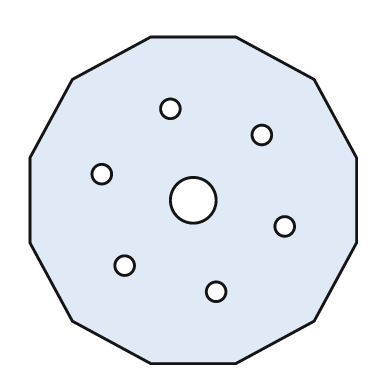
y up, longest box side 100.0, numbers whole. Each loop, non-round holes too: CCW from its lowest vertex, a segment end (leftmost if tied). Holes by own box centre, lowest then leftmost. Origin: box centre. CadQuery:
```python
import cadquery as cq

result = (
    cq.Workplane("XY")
    .moveTo(-13.0, -50.0)
    .lineTo(13.0, -50.0)
    .lineTo(37.0, -37.0)
    .lineTo(50.0, -13.0)
    .lineTo(50.0, 13.0)
    .lineTo(37.0, 37.0)
    .lineTo(13.0, 50.0)
    .lineTo(-13.0, 50.0)
    .lineTo(-37.0, 37.0)
    .lineTo(-50.0, 13.0)
    .lineTo(-50.0, -13.0)
    .lineTo(-37.0, -37.0)
    .close()
    .moveTo(7.0, -28.0)
    .circle(3.0)
    .moveTo(-21.0, -20.0)
    .circle(3.0)
    .moveTo(28.0, -8.0)
    .circle(3.0)
    .moveTo(0.0, 0.0)
    .circle(7.0)
    .moveTo(-28.0, 8.0)
    .circle(3.0)
    .moveTo(21.0, 20.0)
    .circle(3.0)
    .moveTo(-7.0, 28.0)
    .circle(3.0)
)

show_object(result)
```